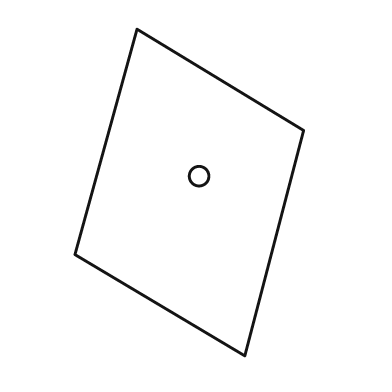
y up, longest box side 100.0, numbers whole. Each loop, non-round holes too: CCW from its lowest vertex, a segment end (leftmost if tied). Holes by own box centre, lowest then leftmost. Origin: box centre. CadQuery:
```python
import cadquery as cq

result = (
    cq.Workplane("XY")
    .moveTo(17.0, -50.0)
    .lineTo(35.0, 19.0)
    .lineTo(-16.0, 50.0)
    .lineTo(-35.0, -19.0)
    .close()
    .moveTo(3.0, 5.0)
    .circle(3.0)
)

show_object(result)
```